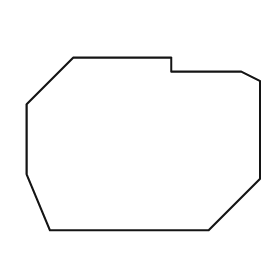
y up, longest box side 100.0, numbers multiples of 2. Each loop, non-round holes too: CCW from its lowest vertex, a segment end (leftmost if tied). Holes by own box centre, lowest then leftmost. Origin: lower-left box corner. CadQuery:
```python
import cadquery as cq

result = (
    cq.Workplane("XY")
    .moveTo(10.0, 0.0)
    .lineTo(78.0, 0.0)
    .lineTo(100.0, 22.0)
    .lineTo(100.0, 64.0)
    .lineTo(92.0, 68.0)
    .lineTo(62.0, 68.0)
    .lineTo(62.0, 74.0)
    .lineTo(20.0, 74.0)
    .lineTo(0.0, 54.0)
    .lineTo(0.0, 24.0)
    .close()
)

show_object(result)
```